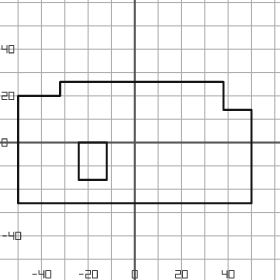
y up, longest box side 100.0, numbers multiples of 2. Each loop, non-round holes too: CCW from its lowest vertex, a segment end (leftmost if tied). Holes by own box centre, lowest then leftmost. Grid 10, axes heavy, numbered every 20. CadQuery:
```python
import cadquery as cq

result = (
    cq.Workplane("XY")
    .moveTo(-50.0, -26.0)
    .lineTo(50.0, -26.0)
    .lineTo(50.0, 14.0)
    .lineTo(38.0, 14.0)
    .lineTo(38.0, 26.0)
    .lineTo(-32.0, 26.0)
    .lineTo(-32.0, 20.0)
    .lineTo(-50.0, 20.0)
    .close()
    .moveTo(-24.0, -16.0)
    .lineTo(-12.0, -16.0)
    .lineTo(-12.0, 0.0)
    .lineTo(-24.0, 0.0)
    .close()
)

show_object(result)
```